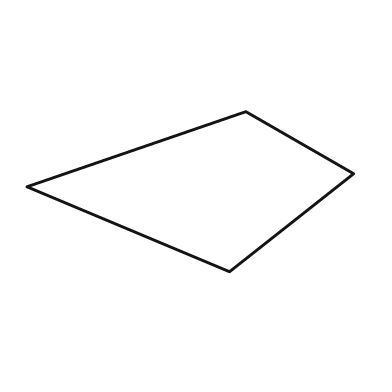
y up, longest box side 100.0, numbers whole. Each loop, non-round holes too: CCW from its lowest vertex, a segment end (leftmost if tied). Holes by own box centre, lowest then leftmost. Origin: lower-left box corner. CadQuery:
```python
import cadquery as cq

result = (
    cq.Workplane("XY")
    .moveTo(62.0, 0.0)
    .lineTo(100.0, 30.0)
    .lineTo(67.0, 49.0)
    .lineTo(0.0, 26.0)
    .close()
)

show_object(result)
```